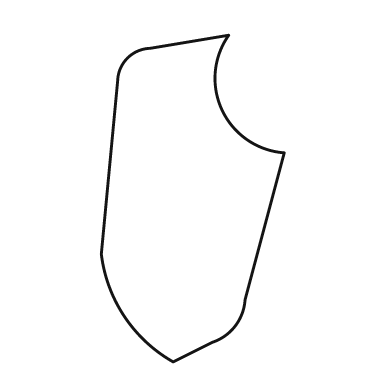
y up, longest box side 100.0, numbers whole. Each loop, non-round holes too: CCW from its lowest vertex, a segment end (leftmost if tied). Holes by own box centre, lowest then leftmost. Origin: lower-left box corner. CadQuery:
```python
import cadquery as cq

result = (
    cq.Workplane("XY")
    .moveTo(22.0, 0.0)
    .lineTo(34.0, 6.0)
    .threePointArc((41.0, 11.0), (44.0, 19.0))
    .lineTo(56.0, 64.0)
    .threePointArc((37.0, 77.0), (39.0, 100.0))
    .lineTo(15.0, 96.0)
    .threePointArc((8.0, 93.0), (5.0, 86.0))
    .lineTo(0.0, 33.0)
    .threePointArc((7.0, 14.0), (22.0, 0.0))
    .close()
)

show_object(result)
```